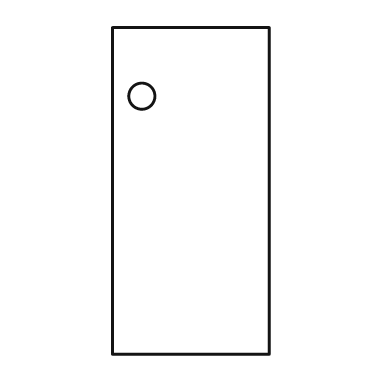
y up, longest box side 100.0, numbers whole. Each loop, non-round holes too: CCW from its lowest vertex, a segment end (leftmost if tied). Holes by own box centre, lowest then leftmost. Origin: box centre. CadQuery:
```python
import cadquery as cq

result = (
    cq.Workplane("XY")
    .moveTo(-24.0, -50.0)
    .lineTo(24.0, -50.0)
    .lineTo(24.0, 50.0)
    .lineTo(-24.0, 50.0)
    .close()
    .moveTo(-15.0, 29.0)
    .circle(4.0)
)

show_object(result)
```